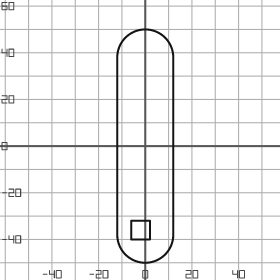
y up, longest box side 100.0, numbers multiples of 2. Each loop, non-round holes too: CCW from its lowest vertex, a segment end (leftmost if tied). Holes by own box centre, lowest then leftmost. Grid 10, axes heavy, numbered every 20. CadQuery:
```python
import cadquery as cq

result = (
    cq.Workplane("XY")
    .moveTo(-12.0, -38.0)
    .threePointArc((0.0, -50.0), (12.0, -38.0))
    .lineTo(12.0, 38.0)
    .threePointArc((0.0, 50.0), (-12.0, 38.0))
    .close()
    .moveTo(-6.0, -40.0)
    .lineTo(2.0, -40.0)
    .lineTo(2.0, -32.0)
    .lineTo(-6.0, -32.0)
    .close()
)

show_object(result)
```